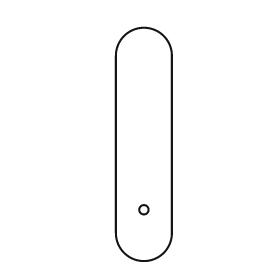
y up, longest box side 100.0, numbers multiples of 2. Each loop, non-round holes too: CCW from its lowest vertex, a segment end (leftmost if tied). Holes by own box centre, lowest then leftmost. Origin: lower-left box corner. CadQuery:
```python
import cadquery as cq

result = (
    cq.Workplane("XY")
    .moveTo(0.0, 12.0)
    .threePointArc((12.0, 0.0), (24.0, 12.0))
    .lineTo(24.0, 88.0)
    .threePointArc((12.0, 100.0), (0.0, 88.0))
    .close()
    .moveTo(12.0, 22.0)
    .circle(2.0)
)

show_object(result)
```